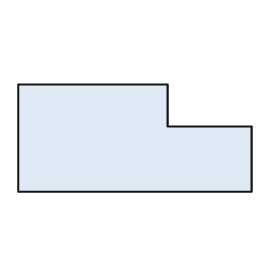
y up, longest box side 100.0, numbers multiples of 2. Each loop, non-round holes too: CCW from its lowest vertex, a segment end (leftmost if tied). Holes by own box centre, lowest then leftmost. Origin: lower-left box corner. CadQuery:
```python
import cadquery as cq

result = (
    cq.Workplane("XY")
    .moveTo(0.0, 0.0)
    .lineTo(100.0, 0.0)
    .lineTo(100.0, 28.0)
    .lineTo(64.0, 28.0)
    .lineTo(64.0, 46.0)
    .lineTo(0.0, 46.0)
    .close()
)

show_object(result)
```